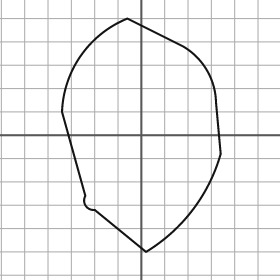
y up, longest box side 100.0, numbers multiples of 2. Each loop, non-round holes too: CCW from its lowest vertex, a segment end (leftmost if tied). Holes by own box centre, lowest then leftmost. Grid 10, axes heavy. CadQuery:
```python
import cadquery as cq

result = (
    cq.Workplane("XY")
    .moveTo(2.0, -50.0)
    .threePointArc((22.0, -32.0), (34.0, -8.0))
    .lineTo(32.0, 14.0)
    .threePointArc((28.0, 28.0), (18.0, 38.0))
    .lineTo(-6.0, 50.0)
    .threePointArc((-26.0, 34.0), (-34.0, 10.0))
    .lineTo(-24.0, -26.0)
    .threePointArc((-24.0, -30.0), (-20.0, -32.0))
    .close()
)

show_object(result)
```